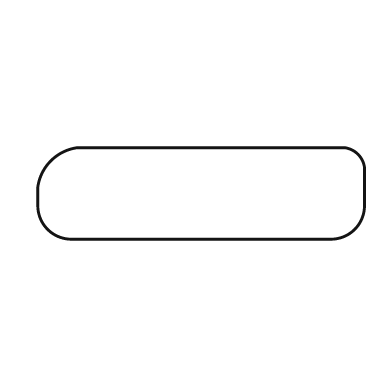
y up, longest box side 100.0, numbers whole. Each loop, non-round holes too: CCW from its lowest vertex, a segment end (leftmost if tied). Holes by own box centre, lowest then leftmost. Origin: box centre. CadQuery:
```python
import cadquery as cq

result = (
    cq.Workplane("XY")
    .moveTo(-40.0, -14.0)
    .lineTo(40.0, -14.0)
    .threePointArc((47.0, -11.0), (50.0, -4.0))
    .lineTo(50.0, 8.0)
    .threePointArc((48.0, 12.0), (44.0, 14.0))
    .lineTo(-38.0, 14.0)
    .threePointArc((-46.0, 10.0), (-50.0, 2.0))
    .lineTo(-50.0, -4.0)
    .threePointArc((-47.0, -11.0), (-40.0, -14.0))
    .close()
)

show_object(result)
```